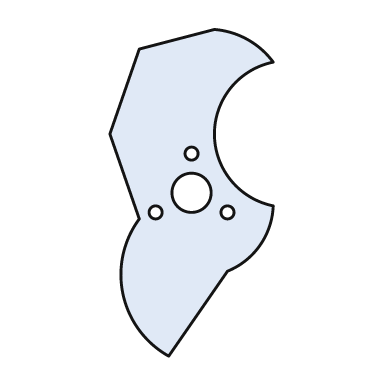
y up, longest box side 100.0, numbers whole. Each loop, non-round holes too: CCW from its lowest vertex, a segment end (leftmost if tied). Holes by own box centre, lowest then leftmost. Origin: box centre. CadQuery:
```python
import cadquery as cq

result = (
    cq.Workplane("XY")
    .moveTo(-7.0, -50.0)
    .lineTo(11.0, -24.0)
    .threePointArc((21.0, -16.0), (25.0, -4.0))
    .threePointArc((7.0, 18.0), (25.0, 40.0))
    .threePointArc((17.0, 47.0), (7.0, 50.0))
    .lineTo(-16.0, 44.0)
    .lineTo(-25.0, 18.0)
    .lineTo(-16.0, -8.0)
    .threePointArc((-21.0, -31.0), (-7.0, -50.0))
    .close()
    .moveTo(-11.0, -6.0)
    .circle(2.0)
    .moveTo(11.0, -6.0)
    .circle(2.0)
    .moveTo(0.0, 0.0)
    .circle(6.0)
    .moveTo(0.0, 12.0)
    .circle(2.0)
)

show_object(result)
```